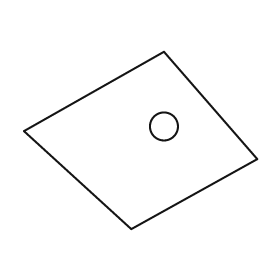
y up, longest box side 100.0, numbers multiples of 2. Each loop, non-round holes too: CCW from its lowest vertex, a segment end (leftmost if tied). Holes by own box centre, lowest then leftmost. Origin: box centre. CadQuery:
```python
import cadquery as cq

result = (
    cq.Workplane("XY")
    .moveTo(-4.0, -38.0)
    .lineTo(50.0, -8.0)
    .lineTo(10.0, 38.0)
    .lineTo(-50.0, 4.0)
    .close()
    .moveTo(10.0, 6.0)
    .circle(6.0)
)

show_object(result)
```